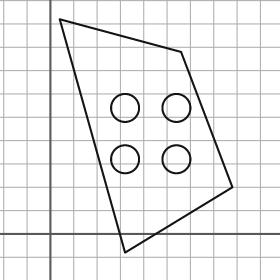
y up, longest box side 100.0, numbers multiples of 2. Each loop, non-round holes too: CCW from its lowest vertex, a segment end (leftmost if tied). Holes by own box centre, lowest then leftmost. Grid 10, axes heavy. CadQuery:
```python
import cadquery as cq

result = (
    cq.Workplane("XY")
    .moveTo(32.0, -8.0)
    .lineTo(78.0, 20.0)
    .lineTo(56.0, 78.0)
    .lineTo(4.0, 92.0)
    .close()
    .moveTo(32.0, 32.0)
    .circle(6.0)
    .moveTo(54.0, 32.0)
    .circle(6.0)
    .moveTo(32.0, 54.0)
    .circle(6.0)
    .moveTo(54.0, 54.0)
    .circle(6.0)
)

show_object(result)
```